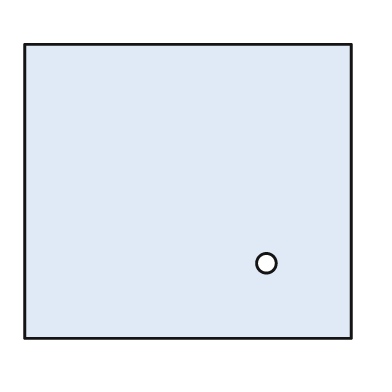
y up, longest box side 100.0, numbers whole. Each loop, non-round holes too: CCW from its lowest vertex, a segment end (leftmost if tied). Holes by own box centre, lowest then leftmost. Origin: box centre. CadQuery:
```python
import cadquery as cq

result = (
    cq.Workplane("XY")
    .moveTo(-50.0, -45.0)
    .lineTo(50.0, -45.0)
    .lineTo(50.0, 45.0)
    .lineTo(-50.0, 45.0)
    .close()
    .moveTo(24.0, -22.0)
    .circle(3.0)
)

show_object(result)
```